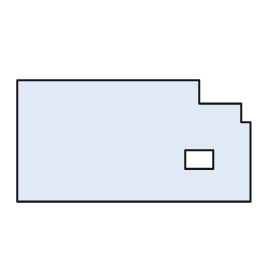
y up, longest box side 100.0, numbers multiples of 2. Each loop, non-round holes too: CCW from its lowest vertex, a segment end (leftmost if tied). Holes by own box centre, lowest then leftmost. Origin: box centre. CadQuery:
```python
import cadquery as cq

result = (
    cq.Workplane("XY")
    .moveTo(-50.0, -26.0)
    .lineTo(50.0, -26.0)
    .lineTo(50.0, 8.0)
    .lineTo(46.0, 8.0)
    .lineTo(46.0, 16.0)
    .lineTo(28.0, 16.0)
    .lineTo(28.0, 26.0)
    .lineTo(-50.0, 26.0)
    .close()
    .moveTo(22.0, -12.0)
    .lineTo(34.0, -12.0)
    .lineTo(34.0, -4.0)
    .lineTo(22.0, -4.0)
    .close()
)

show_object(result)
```